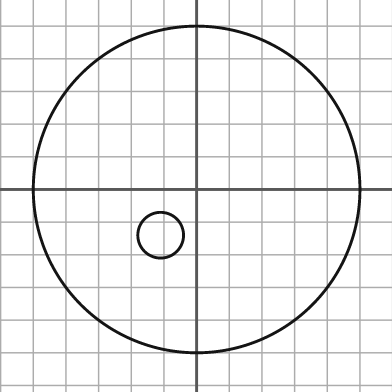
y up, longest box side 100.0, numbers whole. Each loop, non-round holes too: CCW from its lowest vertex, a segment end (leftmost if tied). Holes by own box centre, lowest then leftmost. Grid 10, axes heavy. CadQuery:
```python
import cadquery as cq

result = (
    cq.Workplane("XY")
    .moveTo(0.0, 0.0)
    .circle(50.0)
    .moveTo(-11.0, -14.0)
    .circle(7.0)
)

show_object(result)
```